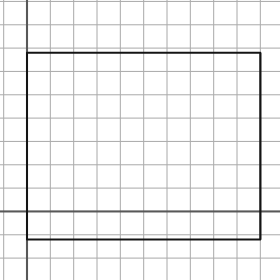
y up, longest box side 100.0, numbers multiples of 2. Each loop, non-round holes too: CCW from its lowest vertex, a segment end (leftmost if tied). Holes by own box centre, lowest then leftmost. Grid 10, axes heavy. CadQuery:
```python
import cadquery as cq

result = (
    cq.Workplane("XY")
    .moveTo(0.0, -12.0)
    .lineTo(100.0, -12.0)
    .lineTo(100.0, 68.0)
    .lineTo(0.0, 68.0)
    .close()
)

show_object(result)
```